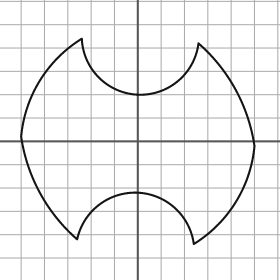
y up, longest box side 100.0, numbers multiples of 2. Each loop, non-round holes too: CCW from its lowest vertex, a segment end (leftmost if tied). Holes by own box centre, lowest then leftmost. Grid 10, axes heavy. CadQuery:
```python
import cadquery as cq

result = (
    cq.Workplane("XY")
    .moveTo(24.0, -44.0)
    .threePointArc((42.0, -26.0), (50.0, -2.0))
    .threePointArc((42.0, 22.0), (26.0, 42.0))
    .threePointArc((0.0, 20.0), (-24.0, 44.0))
    .threePointArc((-42.0, 26.0), (-50.0, 2.0))
    .threePointArc((-42.0, -22.0), (-26.0, -42.0))
    .threePointArc((0.0, -22.0), (24.0, -44.0))
    .close()
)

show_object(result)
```